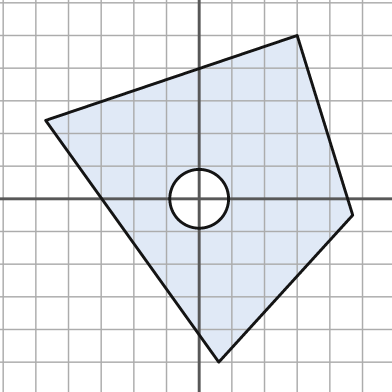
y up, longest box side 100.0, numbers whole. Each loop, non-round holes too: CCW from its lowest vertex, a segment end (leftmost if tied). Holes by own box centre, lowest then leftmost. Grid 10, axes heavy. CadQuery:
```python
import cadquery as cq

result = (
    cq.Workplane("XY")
    .moveTo(6.0, -50.0)
    .lineTo(47.0, -5.0)
    .lineTo(30.0, 50.0)
    .lineTo(-47.0, 24.0)
    .close()
    .moveTo(0.0, 0.0)
    .circle(9.0)
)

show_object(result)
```